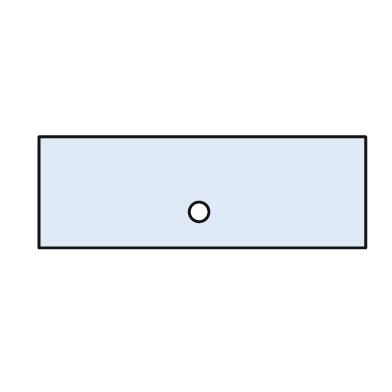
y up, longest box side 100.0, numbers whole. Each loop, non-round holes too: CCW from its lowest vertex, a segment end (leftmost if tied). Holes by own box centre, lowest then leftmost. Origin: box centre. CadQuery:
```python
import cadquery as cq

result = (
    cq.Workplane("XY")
    .moveTo(-50.0, -17.0)
    .lineTo(50.0, -17.0)
    .lineTo(50.0, 17.0)
    .lineTo(-50.0, 17.0)
    .close()
    .moveTo(-1.0, -6.0)
    .circle(3.0)
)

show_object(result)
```